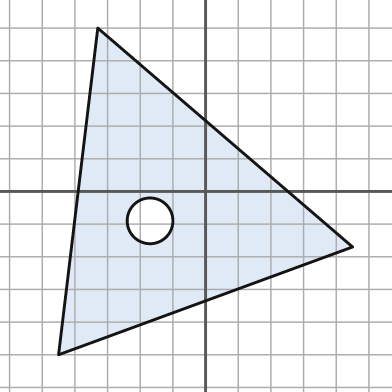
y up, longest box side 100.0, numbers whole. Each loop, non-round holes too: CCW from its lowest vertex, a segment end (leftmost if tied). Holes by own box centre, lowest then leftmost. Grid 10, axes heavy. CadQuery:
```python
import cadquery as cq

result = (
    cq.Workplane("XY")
    .moveTo(-45.0, -50.0)
    .lineTo(45.0, -17.0)
    .lineTo(-33.0, 50.0)
    .close()
    .moveTo(-17.0, -9.0)
    .circle(7.0)
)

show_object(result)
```